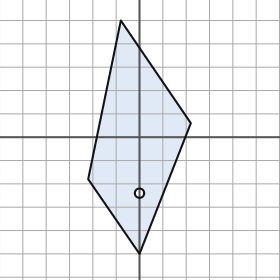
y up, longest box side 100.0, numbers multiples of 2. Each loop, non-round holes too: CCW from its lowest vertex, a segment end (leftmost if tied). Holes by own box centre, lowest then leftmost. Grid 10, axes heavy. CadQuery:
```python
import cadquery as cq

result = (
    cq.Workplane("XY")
    .moveTo(0.0, -50.0)
    .lineTo(22.0, 6.0)
    .lineTo(-8.0, 50.0)
    .lineTo(-22.0, -18.0)
    .close()
    .moveTo(0.0, -24.0)
    .circle(2.0)
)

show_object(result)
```